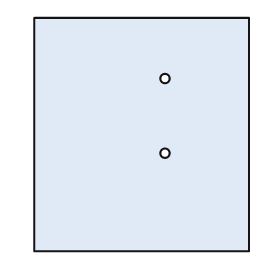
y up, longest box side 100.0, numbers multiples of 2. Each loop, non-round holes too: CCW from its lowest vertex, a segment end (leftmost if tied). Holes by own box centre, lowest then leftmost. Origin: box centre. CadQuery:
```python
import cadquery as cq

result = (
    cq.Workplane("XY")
    .moveTo(-46.0, -50.0)
    .lineTo(46.0, -50.0)
    .lineTo(46.0, 50.0)
    .lineTo(-46.0, 50.0)
    .close()
    .moveTo(10.0, -8.0)
    .circle(2.0)
    .moveTo(10.0, 24.0)
    .circle(2.0)
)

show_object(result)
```